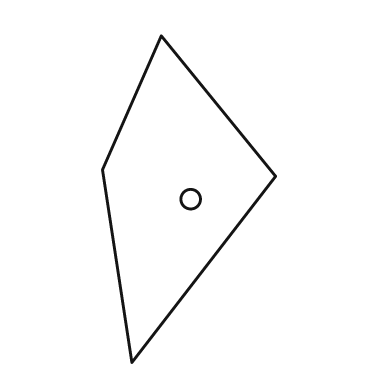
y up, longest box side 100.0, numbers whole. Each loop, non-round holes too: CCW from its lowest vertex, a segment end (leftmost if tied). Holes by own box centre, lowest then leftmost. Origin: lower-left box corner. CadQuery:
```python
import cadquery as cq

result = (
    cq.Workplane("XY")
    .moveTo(9.0, 0.0)
    .lineTo(53.0, 57.0)
    .lineTo(18.0, 100.0)
    .lineTo(0.0, 59.0)
    .close()
    .moveTo(27.0, 50.0)
    .circle(3.0)
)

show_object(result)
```